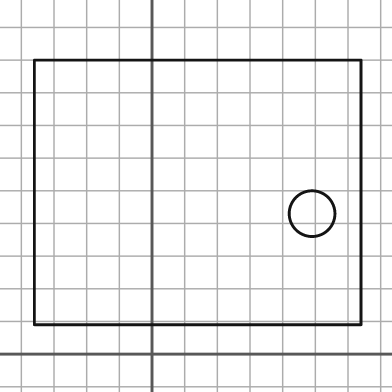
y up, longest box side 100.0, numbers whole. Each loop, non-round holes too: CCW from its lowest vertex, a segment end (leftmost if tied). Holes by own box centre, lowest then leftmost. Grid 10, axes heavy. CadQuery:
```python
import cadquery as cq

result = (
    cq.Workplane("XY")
    .moveTo(-36.0, 9.0)
    .lineTo(64.0, 9.0)
    .lineTo(64.0, 90.0)
    .lineTo(-36.0, 90.0)
    .close()
    .moveTo(49.0, 43.0)
    .circle(7.0)
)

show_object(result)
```